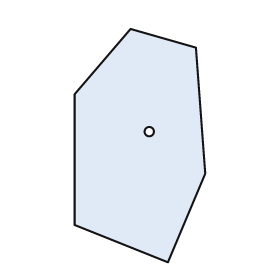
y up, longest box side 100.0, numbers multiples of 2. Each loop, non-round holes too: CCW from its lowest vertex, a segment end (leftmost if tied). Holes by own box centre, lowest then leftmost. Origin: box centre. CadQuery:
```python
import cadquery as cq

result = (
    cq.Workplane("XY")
    .moveTo(12.0, -50.0)
    .lineTo(28.0, -12.0)
    .lineTo(24.0, 42.0)
    .lineTo(-4.0, 50.0)
    .lineTo(-28.0, 22.0)
    .lineTo(-28.0, -34.0)
    .close()
    .moveTo(4.0, 6.0)
    .circle(2.0)
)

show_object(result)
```